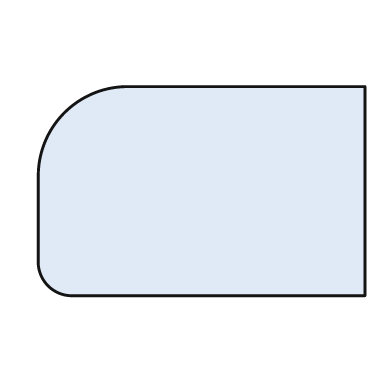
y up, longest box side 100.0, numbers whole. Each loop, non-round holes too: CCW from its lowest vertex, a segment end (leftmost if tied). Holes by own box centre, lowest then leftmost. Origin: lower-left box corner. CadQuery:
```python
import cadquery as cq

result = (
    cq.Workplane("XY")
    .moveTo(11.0, 0.0)
    .lineTo(100.0, 0.0)
    .lineTo(100.0, 64.0)
    .lineTo(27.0, 64.0)
    .threePointArc((8.0, 56.0), (0.0, 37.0))
    .lineTo(0.0, 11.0)
    .threePointArc((3.0, 3.0), (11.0, 0.0))
    .close()
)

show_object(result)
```